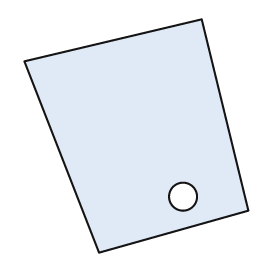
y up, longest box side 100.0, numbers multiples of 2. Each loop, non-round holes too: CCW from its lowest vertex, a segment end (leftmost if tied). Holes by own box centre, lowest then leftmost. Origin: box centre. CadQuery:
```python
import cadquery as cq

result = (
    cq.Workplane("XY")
    .moveTo(-16.0, -50.0)
    .lineTo(48.0, -32.0)
    .lineTo(28.0, 50.0)
    .lineTo(-48.0, 32.0)
    .close()
    .moveTo(20.0, -26.0)
    .circle(6.0)
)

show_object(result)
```